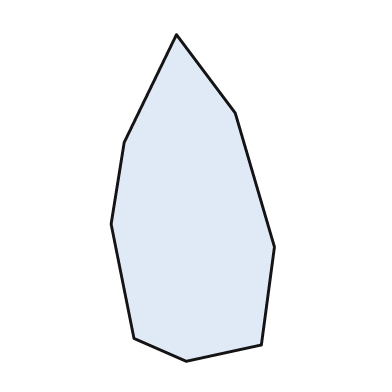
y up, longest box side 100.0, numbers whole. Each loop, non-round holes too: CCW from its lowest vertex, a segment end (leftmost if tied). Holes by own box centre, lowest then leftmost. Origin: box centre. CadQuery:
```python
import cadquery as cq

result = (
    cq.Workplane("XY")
    .moveTo(-2.0, -50.0)
    .lineTo(21.0, -45.0)
    .lineTo(25.0, -15.0)
    .lineTo(13.0, 26.0)
    .lineTo(-5.0, 50.0)
    .lineTo(-21.0, 17.0)
    .lineTo(-25.0, -8.0)
    .lineTo(-18.0, -43.0)
    .close()
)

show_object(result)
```